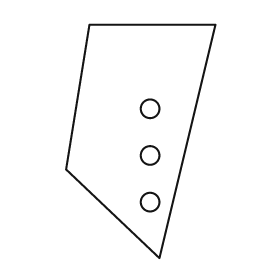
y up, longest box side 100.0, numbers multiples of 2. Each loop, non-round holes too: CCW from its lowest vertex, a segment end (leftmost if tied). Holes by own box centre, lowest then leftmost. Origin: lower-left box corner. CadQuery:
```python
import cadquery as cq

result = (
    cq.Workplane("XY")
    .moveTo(40.0, 0.0)
    .lineTo(64.0, 100.0)
    .lineTo(10.0, 100.0)
    .lineTo(0.0, 38.0)
    .close()
    .moveTo(36.0, 24.0)
    .circle(4.0)
    .moveTo(36.0, 44.0)
    .circle(4.0)
    .moveTo(36.0, 64.0)
    .circle(4.0)
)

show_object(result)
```